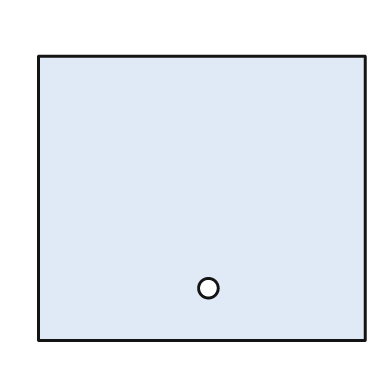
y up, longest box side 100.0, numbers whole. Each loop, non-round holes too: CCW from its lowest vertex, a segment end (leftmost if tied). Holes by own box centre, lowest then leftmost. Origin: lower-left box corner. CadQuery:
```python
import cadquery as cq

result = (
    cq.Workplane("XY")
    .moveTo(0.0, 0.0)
    .lineTo(100.0, 0.0)
    .lineTo(100.0, 87.0)
    .lineTo(0.0, 87.0)
    .close()
    .moveTo(52.0, 16.0)
    .circle(3.0)
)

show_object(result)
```